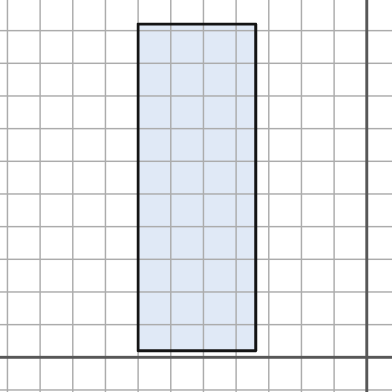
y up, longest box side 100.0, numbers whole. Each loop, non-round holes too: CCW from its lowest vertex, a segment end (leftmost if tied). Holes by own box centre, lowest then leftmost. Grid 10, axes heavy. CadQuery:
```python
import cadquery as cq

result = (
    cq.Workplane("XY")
    .moveTo(-70.0, 2.0)
    .lineTo(-34.0, 2.0)
    .lineTo(-34.0, 102.0)
    .lineTo(-70.0, 102.0)
    .close()
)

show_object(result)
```